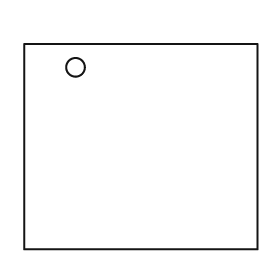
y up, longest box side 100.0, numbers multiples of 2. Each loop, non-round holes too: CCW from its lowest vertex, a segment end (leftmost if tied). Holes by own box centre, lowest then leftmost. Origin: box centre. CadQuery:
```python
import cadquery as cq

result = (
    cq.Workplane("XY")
    .moveTo(-50.0, -44.0)
    .lineTo(50.0, -44.0)
    .lineTo(50.0, 44.0)
    .lineTo(-50.0, 44.0)
    .close()
    .moveTo(-28.0, 34.0)
    .circle(4.0)
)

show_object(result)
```